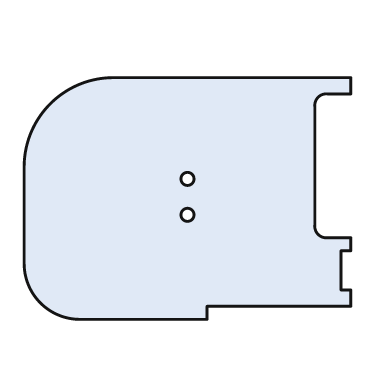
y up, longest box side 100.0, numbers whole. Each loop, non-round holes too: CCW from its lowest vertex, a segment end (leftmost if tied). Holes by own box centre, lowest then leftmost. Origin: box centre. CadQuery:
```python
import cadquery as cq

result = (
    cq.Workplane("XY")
    .moveTo(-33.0, -37.0)
    .lineTo(6.0, -37.0)
    .lineTo(6.0, -33.0)
    .lineTo(50.0, -33.0)
    .lineTo(50.0, -28.0)
    .lineTo(47.0, -28.0)
    .lineTo(47.0, -16.0)
    .lineTo(50.0, -16.0)
    .lineTo(50.0, -12.0)
    .lineTo(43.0, -12.0)
    .threePointArc((40.0, -11.0), (39.0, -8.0))
    .lineTo(39.0, 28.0)
    .threePointArc((40.0, 31.0), (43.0, 32.0))
    .lineTo(50.0, 32.0)
    .lineTo(50.0, 37.0)
    .lineTo(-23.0, 37.0)
    .threePointArc((-42.0, 29.0), (-50.0, 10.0))
    .lineTo(-50.0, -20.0)
    .threePointArc((-45.0, -32.0), (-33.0, -37.0))
    .close()
    .moveTo(0.0, -5.0)
    .circle(2.0)
    .moveTo(0.0, 6.0)
    .circle(2.0)
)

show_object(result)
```